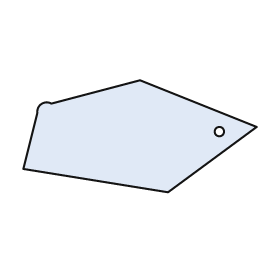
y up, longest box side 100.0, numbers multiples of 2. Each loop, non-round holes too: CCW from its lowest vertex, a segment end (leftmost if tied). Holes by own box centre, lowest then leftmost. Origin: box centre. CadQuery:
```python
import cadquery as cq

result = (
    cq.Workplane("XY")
    .moveTo(12.0, -24.0)
    .lineTo(50.0, 4.0)
    .lineTo(0.0, 24.0)
    .lineTo(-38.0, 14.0)
    .threePointArc((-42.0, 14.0), (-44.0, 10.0))
    .lineTo(-50.0, -14.0)
    .close()
    .moveTo(34.0, 2.0)
    .circle(2.0)
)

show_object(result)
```